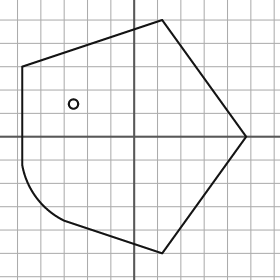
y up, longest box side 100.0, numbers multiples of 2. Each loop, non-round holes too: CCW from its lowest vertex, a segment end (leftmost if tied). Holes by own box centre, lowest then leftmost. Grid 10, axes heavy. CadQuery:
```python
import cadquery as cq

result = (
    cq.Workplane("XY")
    .moveTo(12.0, -50.0)
    .lineTo(48.0, 0.0)
    .lineTo(12.0, 50.0)
    .lineTo(-48.0, 30.0)
    .lineTo(-48.0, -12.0)
    .threePointArc((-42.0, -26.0), (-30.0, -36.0))
    .close()
    .moveTo(-26.0, 14.0)
    .circle(2.0)
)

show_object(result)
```